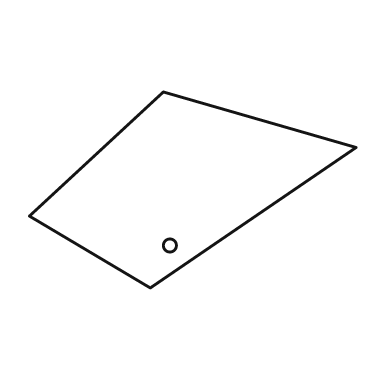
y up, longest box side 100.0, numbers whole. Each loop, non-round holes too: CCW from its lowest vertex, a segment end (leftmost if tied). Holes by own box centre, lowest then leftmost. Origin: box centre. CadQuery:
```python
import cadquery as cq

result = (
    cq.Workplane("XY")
    .moveTo(-13.0, -30.0)
    .lineTo(50.0, 13.0)
    .lineTo(-9.0, 30.0)
    .lineTo(-50.0, -8.0)
    .close()
    .moveTo(-7.0, -17.0)
    .circle(2.0)
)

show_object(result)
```